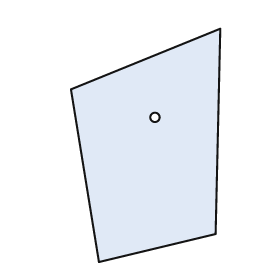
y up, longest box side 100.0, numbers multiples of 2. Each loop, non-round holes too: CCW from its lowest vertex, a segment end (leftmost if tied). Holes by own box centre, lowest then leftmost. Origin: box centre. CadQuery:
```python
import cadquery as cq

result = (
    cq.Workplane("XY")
    .moveTo(-20.0, -50.0)
    .lineTo(30.0, -38.0)
    .lineTo(32.0, 50.0)
    .lineTo(-32.0, 24.0)
    .close()
    .moveTo(4.0, 12.0)
    .circle(2.0)
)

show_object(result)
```